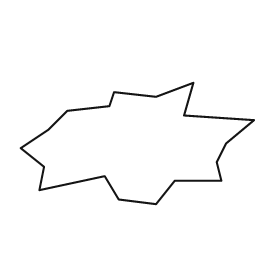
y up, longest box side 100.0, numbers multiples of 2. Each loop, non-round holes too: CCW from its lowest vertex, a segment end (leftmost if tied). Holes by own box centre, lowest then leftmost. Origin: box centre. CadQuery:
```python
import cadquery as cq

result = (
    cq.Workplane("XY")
    .moveTo(8.0, -26.0)
    .lineTo(16.0, -16.0)
    .lineTo(36.0, -16.0)
    .lineTo(34.0, -8.0)
    .lineTo(38.0, 0.0)
    .lineTo(50.0, 10.0)
    .lineTo(20.0, 12.0)
    .lineTo(24.0, 26.0)
    .lineTo(8.0, 20.0)
    .lineTo(-10.0, 22.0)
    .lineTo(-12.0, 16.0)
    .lineTo(-30.0, 14.0)
    .lineTo(-38.0, 6.0)
    .lineTo(-50.0, -2.0)
    .lineTo(-40.0, -10.0)
    .lineTo(-42.0, -20.0)
    .lineTo(-14.0, -14.0)
    .lineTo(-8.0, -24.0)
    .close()
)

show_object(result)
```